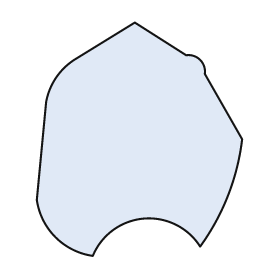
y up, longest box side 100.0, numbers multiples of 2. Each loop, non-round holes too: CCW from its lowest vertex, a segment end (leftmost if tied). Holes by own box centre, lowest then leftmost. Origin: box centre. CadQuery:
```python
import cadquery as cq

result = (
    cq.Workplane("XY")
    .moveTo(-20.0, -50.0)
    .threePointArc((2.0, -34.0), (26.0, -46.0))
    .threePointArc((38.0, -24.0), (44.0, 0.0))
    .lineTo(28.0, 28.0)
    .threePointArc((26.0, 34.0), (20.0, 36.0))
    .lineTo(-2.0, 50.0)
    .lineTo(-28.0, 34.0)
    .threePointArc((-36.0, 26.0), (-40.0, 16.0))
    .lineTo(-44.0, -26.0)
    .threePointArc((-36.0, -42.0), (-20.0, -50.0))
    .close()
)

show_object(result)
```